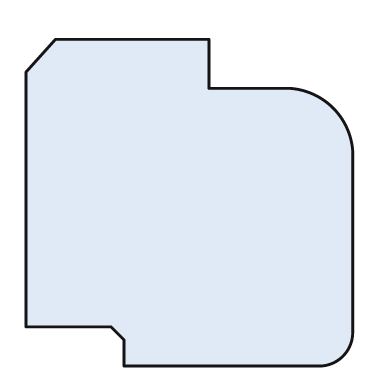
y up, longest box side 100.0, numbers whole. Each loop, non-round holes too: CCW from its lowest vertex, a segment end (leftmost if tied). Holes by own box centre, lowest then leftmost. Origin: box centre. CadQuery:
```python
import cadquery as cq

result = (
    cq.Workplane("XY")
    .moveTo(-20.0, -50.0)
    .lineTo(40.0, -50.0)
    .threePointArc((47.0, -47.0), (50.0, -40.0))
    .lineTo(50.0, 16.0)
    .threePointArc((44.0, 29.0), (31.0, 35.0))
    .lineTo(6.0, 35.0)
    .lineTo(6.0, 50.0)
    .lineTo(-41.0, 50.0)
    .lineTo(-50.0, 40.0)
    .lineTo(-50.0, -38.0)
    .lineTo(-24.0, -38.0)
    .lineTo(-20.0, -42.0)
    .close()
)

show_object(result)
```